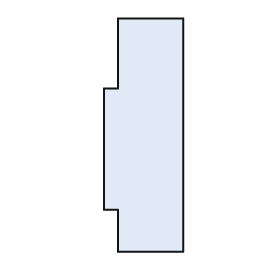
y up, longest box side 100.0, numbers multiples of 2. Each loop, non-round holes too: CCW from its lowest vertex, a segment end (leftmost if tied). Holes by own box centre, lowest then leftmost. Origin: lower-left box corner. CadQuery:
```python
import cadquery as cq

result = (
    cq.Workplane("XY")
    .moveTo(6.0, 0.0)
    .lineTo(34.0, 0.0)
    .lineTo(34.0, 100.0)
    .lineTo(6.0, 100.0)
    .lineTo(6.0, 70.0)
    .lineTo(0.0, 70.0)
    .lineTo(0.0, 18.0)
    .lineTo(6.0, 18.0)
    .close()
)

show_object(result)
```